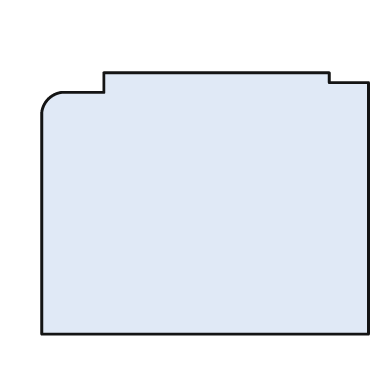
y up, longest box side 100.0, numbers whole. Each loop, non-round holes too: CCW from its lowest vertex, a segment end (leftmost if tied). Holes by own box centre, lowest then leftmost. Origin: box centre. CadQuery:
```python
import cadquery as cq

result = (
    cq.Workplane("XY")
    .moveTo(-50.0, -40.0)
    .lineTo(50.0, -40.0)
    .lineTo(50.0, 37.0)
    .lineTo(38.0, 37.0)
    .lineTo(38.0, 40.0)
    .lineTo(-31.0, 40.0)
    .lineTo(-31.0, 34.0)
    .lineTo(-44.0, 34.0)
    .threePointArc((-48.0, 32.0), (-50.0, 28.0))
    .close()
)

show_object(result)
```